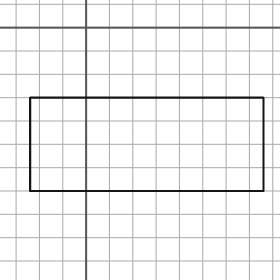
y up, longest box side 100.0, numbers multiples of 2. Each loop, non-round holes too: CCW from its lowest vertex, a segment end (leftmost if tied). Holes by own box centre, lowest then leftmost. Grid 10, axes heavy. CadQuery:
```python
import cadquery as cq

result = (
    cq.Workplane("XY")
    .moveTo(-24.0, -70.0)
    .lineTo(76.0, -70.0)
    .lineTo(76.0, -30.0)
    .lineTo(-24.0, -30.0)
    .close()
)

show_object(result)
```